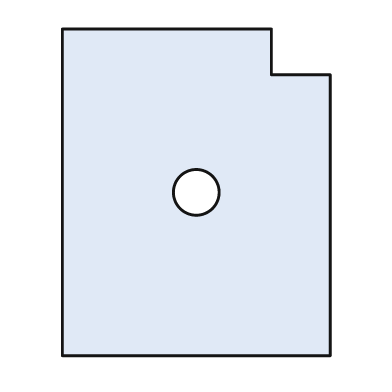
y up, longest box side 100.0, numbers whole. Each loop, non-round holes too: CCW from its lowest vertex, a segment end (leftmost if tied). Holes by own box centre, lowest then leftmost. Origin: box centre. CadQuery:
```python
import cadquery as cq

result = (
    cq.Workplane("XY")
    .moveTo(-41.0, -50.0)
    .lineTo(41.0, -50.0)
    .lineTo(41.0, 36.0)
    .lineTo(23.0, 36.0)
    .lineTo(23.0, 50.0)
    .lineTo(-41.0, 50.0)
    .close()
    .moveTo(0.0, 0.0)
    .circle(7.0)
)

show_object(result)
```